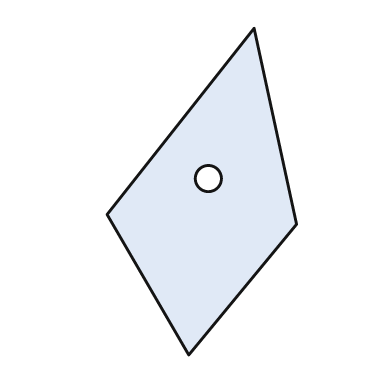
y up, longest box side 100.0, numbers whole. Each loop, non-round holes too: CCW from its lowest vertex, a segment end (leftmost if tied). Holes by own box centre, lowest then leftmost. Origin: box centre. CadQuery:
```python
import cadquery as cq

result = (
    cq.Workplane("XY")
    .moveTo(-4.0, -50.0)
    .lineTo(29.0, -10.0)
    .lineTo(16.0, 50.0)
    .lineTo(-29.0, -7.0)
    .close()
    .moveTo(2.0, 4.0)
    .circle(4.0)
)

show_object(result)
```